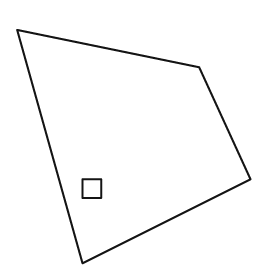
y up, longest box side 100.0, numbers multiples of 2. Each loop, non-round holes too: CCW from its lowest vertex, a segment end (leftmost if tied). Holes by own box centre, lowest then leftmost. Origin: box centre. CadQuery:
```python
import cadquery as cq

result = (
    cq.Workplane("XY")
    .moveTo(-22.0, -50.0)
    .lineTo(50.0, -14.0)
    .lineTo(28.0, 34.0)
    .lineTo(-50.0, 50.0)
    .close()
    .moveTo(-22.0, -22.0)
    .lineTo(-14.0, -22.0)
    .lineTo(-14.0, -14.0)
    .lineTo(-22.0, -14.0)
    .close()
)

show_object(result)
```